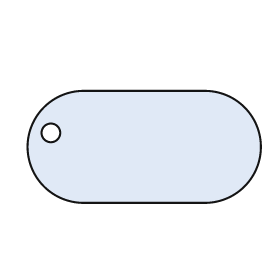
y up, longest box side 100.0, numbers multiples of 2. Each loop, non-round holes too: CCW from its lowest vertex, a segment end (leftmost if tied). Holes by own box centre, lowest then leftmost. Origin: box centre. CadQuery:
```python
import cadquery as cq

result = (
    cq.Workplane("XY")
    .moveTo(-26.0, -24.0)
    .lineTo(26.0, -24.0)
    .threePointArc((50.0, 0.0), (26.0, 24.0))
    .lineTo(-26.0, 24.0)
    .threePointArc((-50.0, 0.0), (-26.0, -24.0))
    .close()
    .moveTo(-40.0, 6.0)
    .circle(4.0)
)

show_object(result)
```